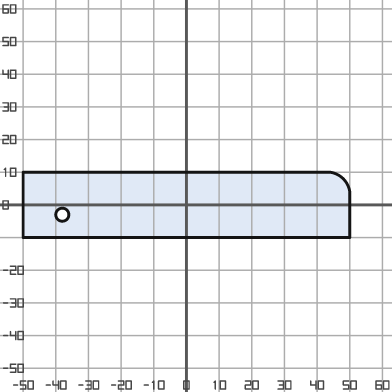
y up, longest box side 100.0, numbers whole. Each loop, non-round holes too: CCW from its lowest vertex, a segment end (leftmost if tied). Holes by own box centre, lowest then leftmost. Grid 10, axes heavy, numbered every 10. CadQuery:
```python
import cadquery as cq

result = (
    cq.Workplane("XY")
    .moveTo(-50.0, -10.0)
    .lineTo(50.0, -10.0)
    .lineTo(50.0, 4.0)
    .threePointArc((48.0, 8.0), (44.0, 10.0))
    .lineTo(-50.0, 10.0)
    .close()
    .moveTo(-38.0, -3.0)
    .circle(2.0)
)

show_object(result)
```